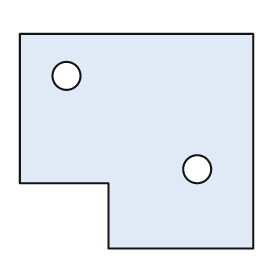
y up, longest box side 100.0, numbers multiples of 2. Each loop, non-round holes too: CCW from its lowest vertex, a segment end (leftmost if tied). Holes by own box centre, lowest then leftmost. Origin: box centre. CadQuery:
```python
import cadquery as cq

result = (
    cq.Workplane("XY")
    .moveTo(-12.0, -46.0)
    .lineTo(50.0, -46.0)
    .lineTo(50.0, 46.0)
    .lineTo(-50.0, 46.0)
    .lineTo(-50.0, -18.0)
    .lineTo(-12.0, -18.0)
    .close()
    .moveTo(26.0, -12.0)
    .circle(6.0)
    .moveTo(-30.0, 28.0)
    .circle(6.0)
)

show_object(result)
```